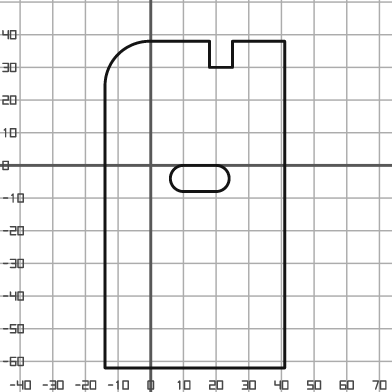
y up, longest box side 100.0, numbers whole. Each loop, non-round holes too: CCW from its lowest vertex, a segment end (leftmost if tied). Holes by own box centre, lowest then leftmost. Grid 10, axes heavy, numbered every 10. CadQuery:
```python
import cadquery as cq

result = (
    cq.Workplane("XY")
    .moveTo(-14.0, -62.0)
    .lineTo(41.0, -62.0)
    .lineTo(41.0, 38.0)
    .lineTo(25.0, 38.0)
    .lineTo(25.0, 30.0)
    .lineTo(18.0, 30.0)
    .lineTo(18.0, 38.0)
    .lineTo(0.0, 38.0)
    .threePointArc((-10.0, 34.0), (-14.0, 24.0))
    .close()
    .moveTo(10.0, -8.0)
    .lineTo(20.0, -8.0)
    .threePointArc((24.0, -4.0), (20.0, 0.0))
    .lineTo(10.0, 0.0)
    .threePointArc((6.0, -4.0), (10.0, -8.0))
    .close()
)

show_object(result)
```